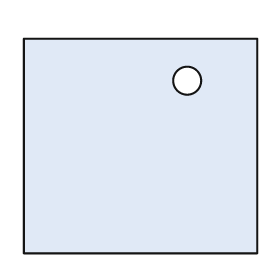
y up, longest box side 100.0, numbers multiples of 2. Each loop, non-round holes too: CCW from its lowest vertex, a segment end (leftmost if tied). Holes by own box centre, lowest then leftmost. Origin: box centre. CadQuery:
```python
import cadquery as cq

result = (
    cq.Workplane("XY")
    .moveTo(-50.0, -46.0)
    .lineTo(50.0, -46.0)
    .lineTo(50.0, 46.0)
    .lineTo(-50.0, 46.0)
    .close()
    .moveTo(20.0, 28.0)
    .circle(6.0)
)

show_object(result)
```